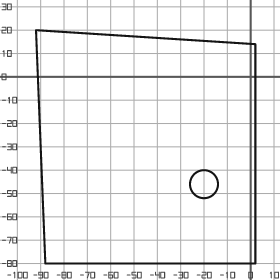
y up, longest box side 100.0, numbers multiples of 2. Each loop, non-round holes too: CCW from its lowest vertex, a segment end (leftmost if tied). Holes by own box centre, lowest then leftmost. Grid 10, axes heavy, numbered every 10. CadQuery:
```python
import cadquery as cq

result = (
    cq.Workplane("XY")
    .moveTo(-88.0, -80.0)
    .lineTo(2.0, -80.0)
    .lineTo(2.0, 14.0)
    .lineTo(-92.0, 20.0)
    .close()
    .moveTo(-20.0, -46.0)
    .circle(6.0)
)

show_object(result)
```